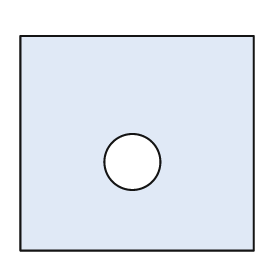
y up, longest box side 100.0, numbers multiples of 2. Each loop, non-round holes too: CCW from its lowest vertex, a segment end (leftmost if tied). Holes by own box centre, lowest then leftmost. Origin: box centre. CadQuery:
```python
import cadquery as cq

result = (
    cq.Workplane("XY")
    .moveTo(-50.0, -46.0)
    .lineTo(50.0, -46.0)
    .lineTo(50.0, 46.0)
    .lineTo(-50.0, 46.0)
    .close()
    .moveTo(-2.0, -8.0)
    .circle(12.0)
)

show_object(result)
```